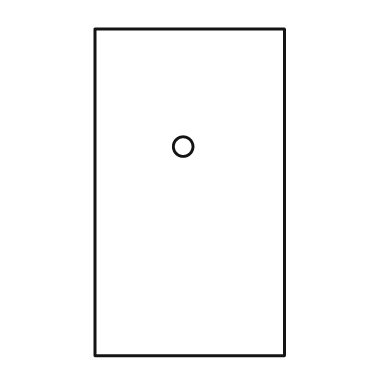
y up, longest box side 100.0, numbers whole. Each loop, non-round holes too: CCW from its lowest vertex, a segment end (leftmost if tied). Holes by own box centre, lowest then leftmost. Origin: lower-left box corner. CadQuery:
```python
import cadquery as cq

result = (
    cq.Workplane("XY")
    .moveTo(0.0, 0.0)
    .lineTo(58.0, 0.0)
    .lineTo(58.0, 100.0)
    .lineTo(0.0, 100.0)
    .close()
    .moveTo(27.0, 64.0)
    .circle(3.0)
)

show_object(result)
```